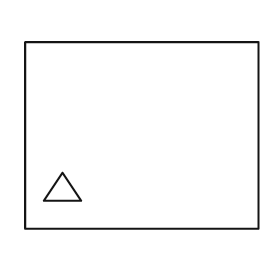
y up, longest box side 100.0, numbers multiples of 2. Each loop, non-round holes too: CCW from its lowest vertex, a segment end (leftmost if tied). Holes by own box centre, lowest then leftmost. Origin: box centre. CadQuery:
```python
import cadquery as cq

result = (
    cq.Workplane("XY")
    .moveTo(-50.0, -40.0)
    .lineTo(50.0, -40.0)
    .lineTo(50.0, 40.0)
    .lineTo(-50.0, 40.0)
    .close()
    .moveTo(-42.0, -28.0)
    .lineTo(-26.0, -28.0)
    .lineTo(-34.0, -16.0)
    .close()
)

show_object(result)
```